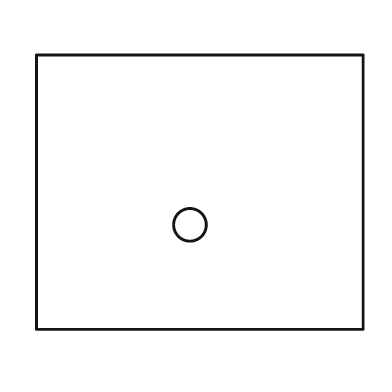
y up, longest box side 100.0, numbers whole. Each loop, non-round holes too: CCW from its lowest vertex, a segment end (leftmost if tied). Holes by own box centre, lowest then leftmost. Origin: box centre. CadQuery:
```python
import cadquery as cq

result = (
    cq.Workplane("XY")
    .moveTo(-50.0, -42.0)
    .lineTo(50.0, -42.0)
    .lineTo(50.0, 42.0)
    .lineTo(-50.0, 42.0)
    .close()
    .moveTo(-3.0, -10.0)
    .circle(5.0)
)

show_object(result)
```